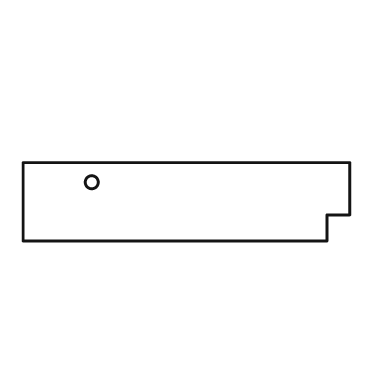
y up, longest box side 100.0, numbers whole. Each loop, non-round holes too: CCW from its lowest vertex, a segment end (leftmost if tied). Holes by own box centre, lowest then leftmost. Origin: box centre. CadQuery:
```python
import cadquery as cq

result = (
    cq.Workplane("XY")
    .moveTo(-50.0, -12.0)
    .lineTo(43.0, -12.0)
    .lineTo(43.0, -4.0)
    .lineTo(50.0, -4.0)
    .lineTo(50.0, 12.0)
    .lineTo(-50.0, 12.0)
    .close()
    .moveTo(-29.0, 6.0)
    .circle(2.0)
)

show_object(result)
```